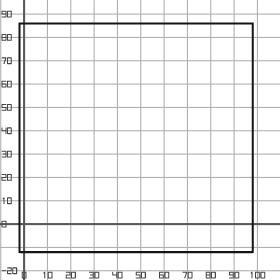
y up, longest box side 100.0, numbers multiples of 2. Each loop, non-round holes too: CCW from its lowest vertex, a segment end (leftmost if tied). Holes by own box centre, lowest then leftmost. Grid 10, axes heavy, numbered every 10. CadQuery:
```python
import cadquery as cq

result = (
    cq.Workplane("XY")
    .moveTo(-2.0, -12.0)
    .lineTo(98.0, -12.0)
    .lineTo(98.0, 86.0)
    .lineTo(-2.0, 86.0)
    .close()
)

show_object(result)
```